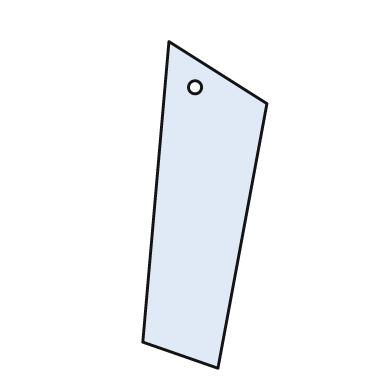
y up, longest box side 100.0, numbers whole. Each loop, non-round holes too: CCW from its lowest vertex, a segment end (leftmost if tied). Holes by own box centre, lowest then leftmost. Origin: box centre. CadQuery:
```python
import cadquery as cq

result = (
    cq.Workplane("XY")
    .moveTo(4.0, -50.0)
    .lineTo(19.0, 31.0)
    .lineTo(-11.0, 50.0)
    .lineTo(-19.0, -42.0)
    .close()
    .moveTo(-3.0, 36.0)
    .circle(2.0)
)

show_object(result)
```